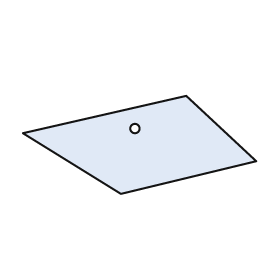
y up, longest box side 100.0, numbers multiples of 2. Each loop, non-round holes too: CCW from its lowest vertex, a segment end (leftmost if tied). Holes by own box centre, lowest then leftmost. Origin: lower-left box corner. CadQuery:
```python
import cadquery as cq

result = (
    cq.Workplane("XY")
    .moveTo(42.0, 0.0)
    .lineTo(100.0, 14.0)
    .lineTo(70.0, 42.0)
    .lineTo(0.0, 26.0)
    .close()
    .moveTo(48.0, 28.0)
    .circle(2.0)
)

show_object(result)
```